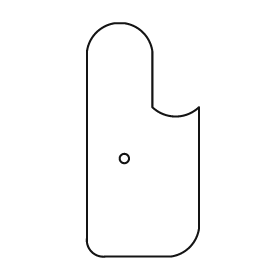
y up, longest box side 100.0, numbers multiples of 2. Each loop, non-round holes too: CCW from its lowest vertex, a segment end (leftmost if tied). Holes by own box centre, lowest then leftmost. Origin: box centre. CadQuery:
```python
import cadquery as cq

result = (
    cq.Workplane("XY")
    .moveTo(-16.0, -50.0)
    .lineTo(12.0, -50.0)
    .threePointArc((20.0, -46.0), (24.0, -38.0))
    .lineTo(24.0, 14.0)
    .threePointArc((14.0, 10.0), (4.0, 14.0))
    .lineTo(4.0, 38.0)
    .threePointArc((0.0, 46.0), (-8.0, 50.0))
    .lineTo(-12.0, 50.0)
    .threePointArc((-20.0, 46.0), (-24.0, 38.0))
    .lineTo(-24.0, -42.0)
    .threePointArc((-22.0, -48.0), (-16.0, -50.0))
    .close()
    .moveTo(-8.0, -8.0)
    .circle(2.0)
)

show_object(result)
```